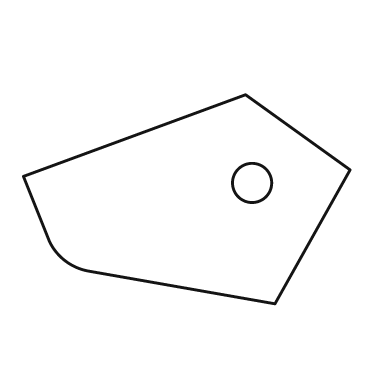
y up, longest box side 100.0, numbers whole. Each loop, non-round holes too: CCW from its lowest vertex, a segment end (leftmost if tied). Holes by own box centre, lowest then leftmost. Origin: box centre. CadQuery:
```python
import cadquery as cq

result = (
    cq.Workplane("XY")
    .moveTo(27.0, -32.0)
    .lineTo(50.0, 9.0)
    .lineTo(18.0, 32.0)
    .lineTo(-50.0, 7.0)
    .lineTo(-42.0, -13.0)
    .threePointArc((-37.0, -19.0), (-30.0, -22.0))
    .close()
    .moveTo(20.0, 5.0)
    .circle(6.0)
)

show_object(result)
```